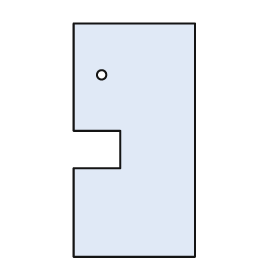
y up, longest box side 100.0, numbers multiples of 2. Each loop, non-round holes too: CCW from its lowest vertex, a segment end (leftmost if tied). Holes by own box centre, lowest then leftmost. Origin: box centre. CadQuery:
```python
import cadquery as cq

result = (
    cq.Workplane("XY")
    .moveTo(-26.0, -50.0)
    .lineTo(26.0, -50.0)
    .lineTo(26.0, 50.0)
    .lineTo(-26.0, 50.0)
    .lineTo(-26.0, 4.0)
    .lineTo(-6.0, 4.0)
    .lineTo(-6.0, -12.0)
    .lineTo(-26.0, -12.0)
    .close()
    .moveTo(-14.0, 28.0)
    .circle(2.0)
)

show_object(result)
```